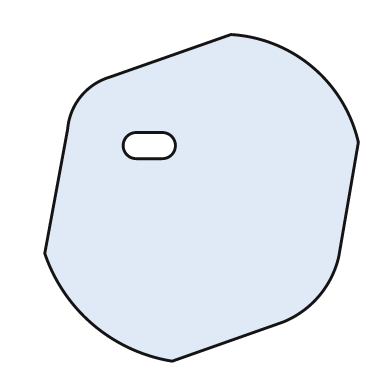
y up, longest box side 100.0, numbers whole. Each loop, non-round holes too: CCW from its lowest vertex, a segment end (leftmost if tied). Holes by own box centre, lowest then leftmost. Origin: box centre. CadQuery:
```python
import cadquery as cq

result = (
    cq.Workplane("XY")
    .moveTo(-9.0, -50.0)
    .lineTo(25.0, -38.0)
    .threePointArc((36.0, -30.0), (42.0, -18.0))
    .lineTo(48.0, 17.0)
    .threePointArc((34.0, 40.0), (9.0, 50.0))
    .lineTo(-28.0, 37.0)
    .threePointArc((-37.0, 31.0), (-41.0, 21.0))
    .lineTo(-48.0, -17.0)
    .threePointArc((-33.0, -39.0), (-9.0, -50.0))
    .close()
    .moveTo(-20.0, 12.0)
    .lineTo(-12.0, 12.0)
    .threePointArc((-8.0, 16.0), (-12.0, 20.0))
    .lineTo(-20.0, 20.0)
    .threePointArc((-24.0, 16.0), (-20.0, 12.0))
    .close()
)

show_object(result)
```